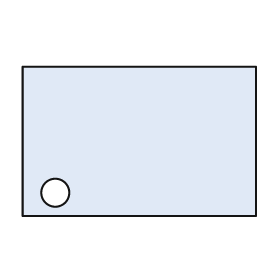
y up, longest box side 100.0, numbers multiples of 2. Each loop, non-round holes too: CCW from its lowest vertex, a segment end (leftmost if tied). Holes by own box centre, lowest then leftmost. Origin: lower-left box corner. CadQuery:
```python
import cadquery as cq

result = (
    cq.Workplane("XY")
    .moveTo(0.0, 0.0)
    .lineTo(100.0, 0.0)
    .lineTo(100.0, 64.0)
    .lineTo(0.0, 64.0)
    .close()
    .moveTo(14.0, 10.0)
    .circle(6.0)
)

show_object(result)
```